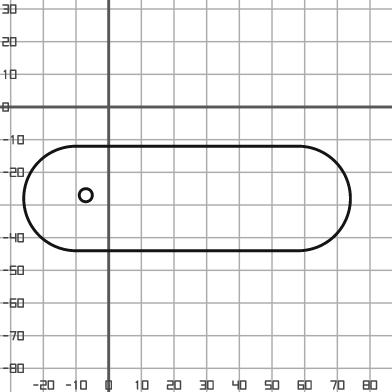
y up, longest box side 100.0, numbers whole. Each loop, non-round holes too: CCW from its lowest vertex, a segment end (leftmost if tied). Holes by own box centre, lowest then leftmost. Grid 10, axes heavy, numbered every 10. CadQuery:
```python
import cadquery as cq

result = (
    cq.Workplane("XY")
    .moveTo(-10.0, -44.0)
    .lineTo(58.0, -44.0)
    .threePointArc((74.0, -28.0), (58.0, -12.0))
    .lineTo(-10.0, -12.0)
    .threePointArc((-26.0, -28.0), (-10.0, -44.0))
    .close()
    .moveTo(-7.0, -27.0)
    .circle(2.0)
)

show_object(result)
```